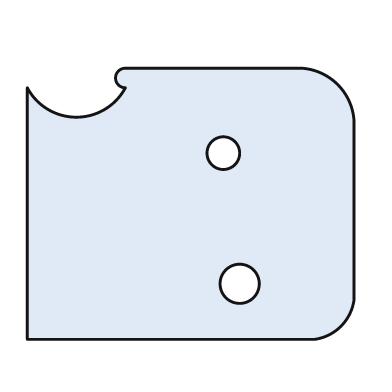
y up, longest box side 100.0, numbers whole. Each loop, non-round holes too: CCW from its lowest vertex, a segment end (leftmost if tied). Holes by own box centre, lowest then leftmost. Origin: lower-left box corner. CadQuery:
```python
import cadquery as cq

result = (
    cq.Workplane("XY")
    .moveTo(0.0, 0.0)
    .lineTo(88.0, 0.0)
    .threePointArc((96.0, 4.0), (100.0, 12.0))
    .lineTo(100.0, 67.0)
    .threePointArc((95.0, 78.0), (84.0, 83.0))
    .lineTo(30.0, 83.0)
    .threePointArc((27.0, 80.0), (30.0, 77.0))
    .threePointArc((15.0, 68.0), (0.0, 77.0))
    .close()
    .moveTo(65.0, 17.0)
    .circle(6.0)
    .moveTo(60.0, 57.0)
    .circle(5.0)
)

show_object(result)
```